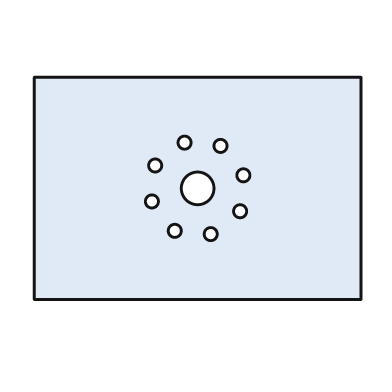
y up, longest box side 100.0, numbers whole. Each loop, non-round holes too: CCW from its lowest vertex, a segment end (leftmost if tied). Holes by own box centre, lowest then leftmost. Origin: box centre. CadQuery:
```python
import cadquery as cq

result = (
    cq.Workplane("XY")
    .moveTo(-50.0, -34.0)
    .lineTo(50.0, -34.0)
    .lineTo(50.0, 34.0)
    .lineTo(-50.0, 34.0)
    .close()
    .moveTo(4.0, -14.0)
    .circle(2.0)
    .moveTo(-7.0, -13.0)
    .circle(2.0)
    .moveTo(13.0, -7.0)
    .circle(2.0)
    .moveTo(-14.0, -4.0)
    .circle(2.0)
    .moveTo(0.0, 0.0)
    .circle(5.0)
    .moveTo(14.0, 4.0)
    .circle(2.0)
    .moveTo(-13.0, 7.0)
    .circle(2.0)
    .moveTo(7.0, 13.0)
    .circle(2.0)
    .moveTo(-4.0, 14.0)
    .circle(2.0)
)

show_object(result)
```